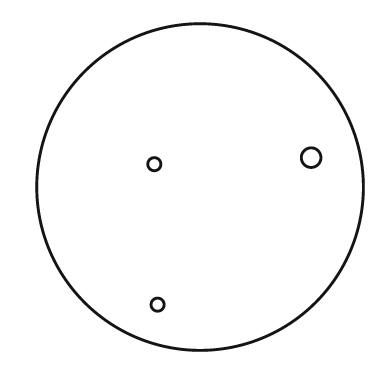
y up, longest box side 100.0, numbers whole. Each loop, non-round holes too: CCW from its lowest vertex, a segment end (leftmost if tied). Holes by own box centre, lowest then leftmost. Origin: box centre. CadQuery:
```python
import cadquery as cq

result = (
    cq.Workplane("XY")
    .moveTo(0.0, 0.0)
    .circle(50.0)
    .moveTo(-13.0, -36.0)
    .circle(2.0)
    .moveTo(-14.0, 7.0)
    .circle(2.0)
    .moveTo(34.0, 9.0)
    .circle(3.0)
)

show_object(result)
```